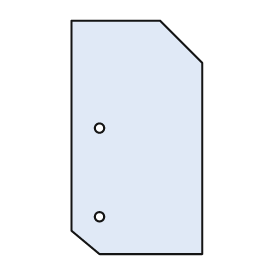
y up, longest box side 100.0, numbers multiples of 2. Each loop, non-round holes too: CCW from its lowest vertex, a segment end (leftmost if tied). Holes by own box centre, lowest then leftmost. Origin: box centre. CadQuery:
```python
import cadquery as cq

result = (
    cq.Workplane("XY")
    .moveTo(-16.0, -50.0)
    .lineTo(28.0, -50.0)
    .lineTo(28.0, 32.0)
    .lineTo(10.0, 50.0)
    .lineTo(-28.0, 50.0)
    .lineTo(-28.0, -40.0)
    .close()
    .moveTo(-16.0, -34.0)
    .circle(2.0)
    .moveTo(-16.0, 4.0)
    .circle(2.0)
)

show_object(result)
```